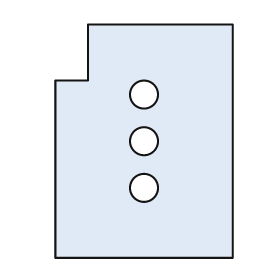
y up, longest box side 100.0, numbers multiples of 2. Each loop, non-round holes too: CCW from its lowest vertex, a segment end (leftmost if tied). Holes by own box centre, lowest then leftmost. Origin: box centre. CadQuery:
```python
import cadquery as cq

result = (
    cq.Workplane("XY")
    .moveTo(-38.0, -50.0)
    .lineTo(38.0, -50.0)
    .lineTo(38.0, 50.0)
    .lineTo(-24.0, 50.0)
    .lineTo(-24.0, 26.0)
    .lineTo(-38.0, 26.0)
    .close()
    .moveTo(0.0, -20.0)
    .circle(6.0)
    .moveTo(0.0, 0.0)
    .circle(6.0)
    .moveTo(0.0, 20.0)
    .circle(6.0)
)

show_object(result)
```